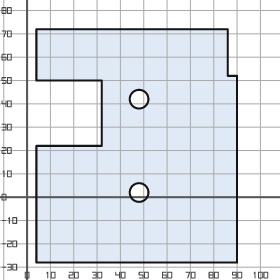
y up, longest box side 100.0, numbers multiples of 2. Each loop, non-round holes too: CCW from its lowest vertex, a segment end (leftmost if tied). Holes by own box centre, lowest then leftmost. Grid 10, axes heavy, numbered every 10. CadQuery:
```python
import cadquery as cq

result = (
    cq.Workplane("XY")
    .moveTo(4.0, -28.0)
    .lineTo(90.0, -28.0)
    .lineTo(90.0, 52.0)
    .lineTo(86.0, 52.0)
    .lineTo(86.0, 72.0)
    .lineTo(4.0, 72.0)
    .lineTo(4.0, 50.0)
    .lineTo(32.0, 50.0)
    .lineTo(32.0, 22.0)
    .lineTo(4.0, 22.0)
    .close()
    .moveTo(48.0, 2.0)
    .circle(4.0)
    .moveTo(48.0, 42.0)
    .circle(4.0)
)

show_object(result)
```